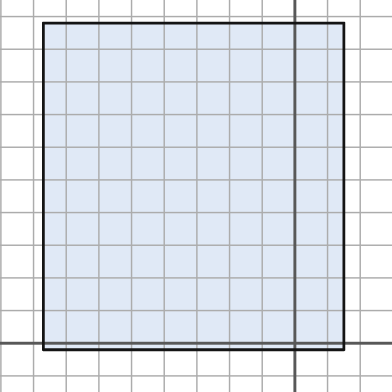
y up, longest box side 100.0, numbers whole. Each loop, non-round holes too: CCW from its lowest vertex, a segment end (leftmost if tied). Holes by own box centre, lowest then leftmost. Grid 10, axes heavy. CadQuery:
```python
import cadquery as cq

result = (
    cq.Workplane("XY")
    .moveTo(-77.0, -2.0)
    .lineTo(15.0, -2.0)
    .lineTo(15.0, 98.0)
    .lineTo(-77.0, 98.0)
    .close()
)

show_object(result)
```